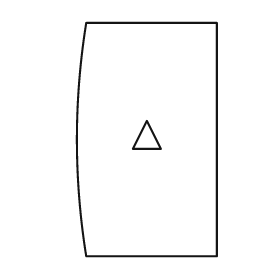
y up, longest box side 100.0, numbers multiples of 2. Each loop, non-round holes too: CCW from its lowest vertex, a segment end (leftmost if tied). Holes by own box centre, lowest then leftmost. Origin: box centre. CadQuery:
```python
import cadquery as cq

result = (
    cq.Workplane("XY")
    .moveTo(-26.0, -50.0)
    .lineTo(30.0, -50.0)
    .lineTo(30.0, 50.0)
    .lineTo(-26.0, 50.0)
    .threePointArc((-30.0, 0.0), (-26.0, -50.0))
    .close()
    .moveTo(-6.0, -4.0)
    .lineTo(6.0, -4.0)
    .lineTo(0.0, 8.0)
    .close()
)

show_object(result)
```